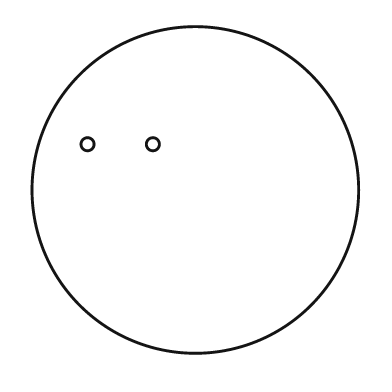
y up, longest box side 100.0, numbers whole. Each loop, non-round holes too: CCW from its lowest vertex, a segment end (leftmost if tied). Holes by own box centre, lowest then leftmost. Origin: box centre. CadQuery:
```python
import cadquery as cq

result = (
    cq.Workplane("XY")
    .moveTo(0.0, 0.0)
    .circle(50.0)
    .moveTo(-33.0, 14.0)
    .circle(2.0)
    .moveTo(-13.0, 14.0)
    .circle(2.0)
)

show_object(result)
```